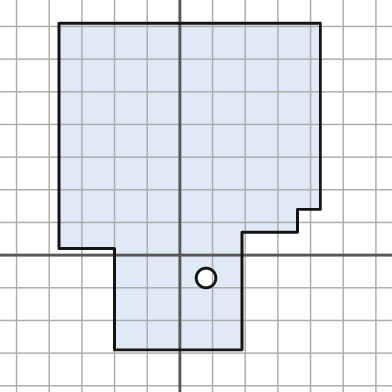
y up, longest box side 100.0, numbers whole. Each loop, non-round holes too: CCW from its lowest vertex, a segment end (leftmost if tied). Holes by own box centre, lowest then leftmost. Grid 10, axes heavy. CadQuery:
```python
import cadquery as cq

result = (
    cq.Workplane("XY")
    .moveTo(-20.0, -29.0)
    .lineTo(19.0, -29.0)
    .lineTo(19.0, 7.0)
    .lineTo(36.0, 7.0)
    .lineTo(36.0, 14.0)
    .lineTo(43.0, 14.0)
    .lineTo(43.0, 71.0)
    .lineTo(-37.0, 71.0)
    .lineTo(-37.0, 2.0)
    .lineTo(-20.0, 2.0)
    .close()
    .moveTo(8.0, -7.0)
    .circle(3.0)
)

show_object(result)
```